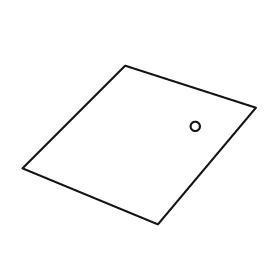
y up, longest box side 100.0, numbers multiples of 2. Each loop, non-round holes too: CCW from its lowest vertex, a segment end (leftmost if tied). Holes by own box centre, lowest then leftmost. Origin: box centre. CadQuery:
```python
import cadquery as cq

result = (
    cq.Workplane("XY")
    .moveTo(8.0, -34.0)
    .lineTo(50.0, 16.0)
    .lineTo(-6.0, 34.0)
    .lineTo(-50.0, -10.0)
    .close()
    .moveTo(24.0, 8.0)
    .circle(2.0)
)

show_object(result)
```